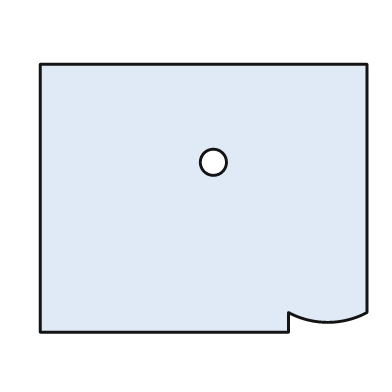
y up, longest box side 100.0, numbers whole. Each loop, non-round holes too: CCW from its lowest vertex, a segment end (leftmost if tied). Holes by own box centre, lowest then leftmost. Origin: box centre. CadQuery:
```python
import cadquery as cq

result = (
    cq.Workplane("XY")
    .moveTo(-50.0, -41.0)
    .lineTo(26.0, -41.0)
    .lineTo(26.0, -35.0)
    .threePointArc((38.0, -38.0), (50.0, -35.0))
    .lineTo(50.0, 41.0)
    .lineTo(-50.0, 41.0)
    .close()
    .moveTo(3.0, 11.0)
    .circle(4.0)
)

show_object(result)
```